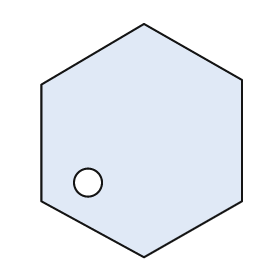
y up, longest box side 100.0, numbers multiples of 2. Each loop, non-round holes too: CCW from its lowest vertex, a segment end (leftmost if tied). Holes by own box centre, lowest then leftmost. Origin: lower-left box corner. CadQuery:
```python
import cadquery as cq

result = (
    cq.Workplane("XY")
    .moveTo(44.0, 0.0)
    .lineTo(86.0, 24.0)
    .lineTo(86.0, 76.0)
    .lineTo(44.0, 100.0)
    .lineTo(0.0, 74.0)
    .lineTo(0.0, 24.0)
    .close()
    .moveTo(20.0, 32.0)
    .circle(6.0)
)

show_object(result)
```